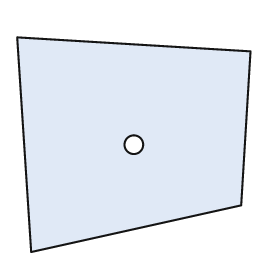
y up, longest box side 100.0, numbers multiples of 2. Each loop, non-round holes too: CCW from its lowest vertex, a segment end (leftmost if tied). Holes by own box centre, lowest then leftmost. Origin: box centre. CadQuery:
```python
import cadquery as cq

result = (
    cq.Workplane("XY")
    .moveTo(-44.0, -46.0)
    .lineTo(46.0, -26.0)
    .lineTo(50.0, 40.0)
    .lineTo(-50.0, 46.0)
    .close()
    .moveTo(0.0, 0.0)
    .circle(4.0)
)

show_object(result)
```